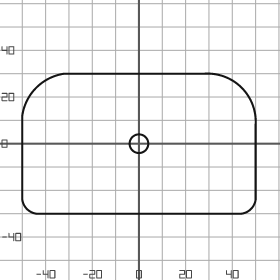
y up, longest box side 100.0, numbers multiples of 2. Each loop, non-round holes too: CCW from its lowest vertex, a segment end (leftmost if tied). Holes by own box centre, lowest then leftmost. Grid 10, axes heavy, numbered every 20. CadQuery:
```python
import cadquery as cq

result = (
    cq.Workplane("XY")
    .moveTo(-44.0, -30.0)
    .lineTo(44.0, -30.0)
    .threePointArc((48.0, -28.0), (50.0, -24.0))
    .lineTo(50.0, 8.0)
    .threePointArc((44.0, 24.0), (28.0, 30.0))
    .lineTo(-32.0, 30.0)
    .threePointArc((-44.0, 24.0), (-50.0, 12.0))
    .lineTo(-50.0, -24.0)
    .threePointArc((-48.0, -28.0), (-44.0, -30.0))
    .close()
    .moveTo(0.0, 0.0)
    .circle(4.0)
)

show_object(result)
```